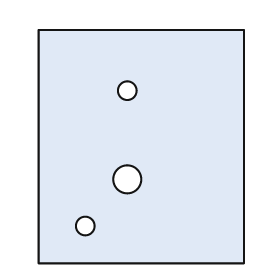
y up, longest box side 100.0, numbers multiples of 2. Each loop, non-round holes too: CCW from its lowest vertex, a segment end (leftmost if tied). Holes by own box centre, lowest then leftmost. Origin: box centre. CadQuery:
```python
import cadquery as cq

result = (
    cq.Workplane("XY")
    .moveTo(-44.0, -50.0)
    .lineTo(44.0, -50.0)
    .lineTo(44.0, 50.0)
    .lineTo(-44.0, 50.0)
    .close()
    .moveTo(-24.0, -34.0)
    .circle(4.0)
    .moveTo(-6.0, -14.0)
    .circle(6.0)
    .moveTo(-6.0, 24.0)
    .circle(4.0)
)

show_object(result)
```